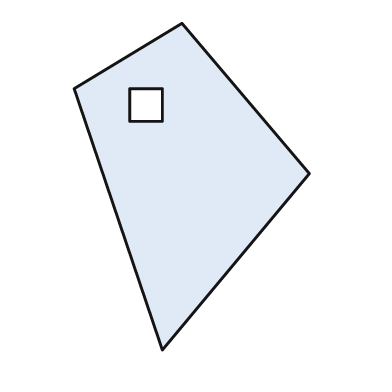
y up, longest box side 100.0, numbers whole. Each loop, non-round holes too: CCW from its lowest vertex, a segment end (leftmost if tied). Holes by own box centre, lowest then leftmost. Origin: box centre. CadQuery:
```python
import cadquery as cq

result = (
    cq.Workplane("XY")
    .moveTo(-9.0, -50.0)
    .lineTo(36.0, 4.0)
    .lineTo(-3.0, 50.0)
    .lineTo(-36.0, 30.0)
    .close()
    .moveTo(-19.0, 20.0)
    .lineTo(-9.0, 20.0)
    .lineTo(-9.0, 30.0)
    .lineTo(-19.0, 30.0)
    .close()
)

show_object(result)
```